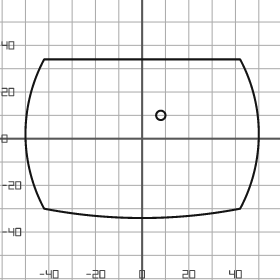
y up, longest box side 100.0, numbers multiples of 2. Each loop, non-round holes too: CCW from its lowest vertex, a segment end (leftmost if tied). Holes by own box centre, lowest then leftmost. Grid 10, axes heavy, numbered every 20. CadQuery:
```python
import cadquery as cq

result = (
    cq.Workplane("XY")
    .moveTo(-42.0, -30.0)
    .threePointArc((0.0, -34.0), (42.0, -30.0))
    .threePointArc((50.0, 2.0), (42.0, 34.0))
    .lineTo(-42.0, 34.0)
    .threePointArc((-50.0, 2.0), (-42.0, -30.0))
    .close()
    .moveTo(8.0, 10.0)
    .circle(2.0)
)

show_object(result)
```